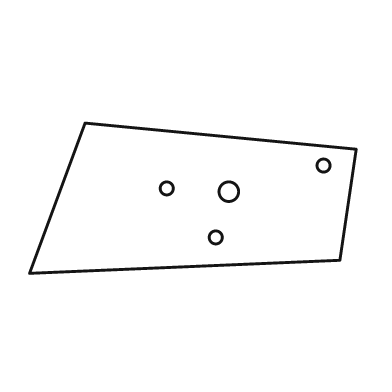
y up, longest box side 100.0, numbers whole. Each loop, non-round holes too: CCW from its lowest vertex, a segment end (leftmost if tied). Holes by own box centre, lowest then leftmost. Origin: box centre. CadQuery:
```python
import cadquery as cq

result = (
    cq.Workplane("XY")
    .moveTo(-50.0, -23.0)
    .lineTo(45.0, -19.0)
    .lineTo(50.0, 15.0)
    .lineTo(-33.0, 23.0)
    .close()
    .moveTo(7.0, -12.0)
    .circle(2.0)
    .moveTo(11.0, 2.0)
    .circle(3.0)
    .moveTo(-8.0, 3.0)
    .circle(2.0)
    .moveTo(40.0, 10.0)
    .circle(2.0)
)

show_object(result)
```